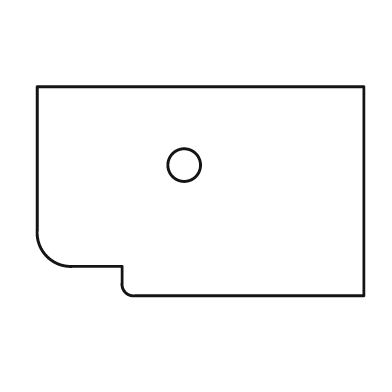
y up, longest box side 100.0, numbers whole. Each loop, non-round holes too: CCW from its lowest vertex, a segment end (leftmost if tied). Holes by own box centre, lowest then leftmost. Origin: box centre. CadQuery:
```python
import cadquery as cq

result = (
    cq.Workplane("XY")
    .moveTo(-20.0, -32.0)
    .lineTo(50.0, -32.0)
    .lineTo(50.0, 32.0)
    .lineTo(-50.0, 32.0)
    .lineTo(-50.0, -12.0)
    .threePointArc((-47.0, -20.0), (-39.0, -23.0))
    .lineTo(-24.0, -23.0)
    .lineTo(-24.0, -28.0)
    .threePointArc((-23.0, -31.0), (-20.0, -32.0))
    .close()
    .moveTo(-5.0, 8.0)
    .circle(5.0)
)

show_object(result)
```